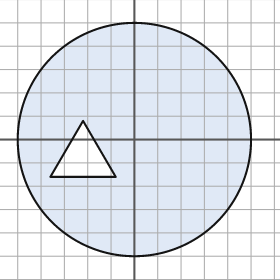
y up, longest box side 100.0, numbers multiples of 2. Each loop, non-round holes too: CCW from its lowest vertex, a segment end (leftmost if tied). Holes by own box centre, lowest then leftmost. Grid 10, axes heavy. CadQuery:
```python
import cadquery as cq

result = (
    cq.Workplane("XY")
    .moveTo(0.0, 0.0)
    .circle(50.0)
    .moveTo(-36.0, -16.0)
    .lineTo(-8.0, -16.0)
    .lineTo(-22.0, 8.0)
    .close()
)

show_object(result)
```